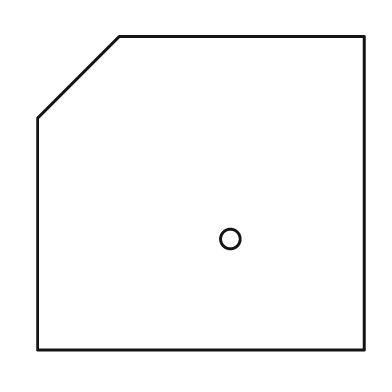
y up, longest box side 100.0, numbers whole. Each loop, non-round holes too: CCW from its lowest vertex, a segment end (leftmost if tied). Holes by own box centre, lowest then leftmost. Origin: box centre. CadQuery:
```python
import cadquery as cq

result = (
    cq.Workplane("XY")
    .moveTo(-50.0, -48.0)
    .lineTo(50.0, -48.0)
    .lineTo(50.0, 48.0)
    .lineTo(-25.0, 48.0)
    .lineTo(-50.0, 23.0)
    .close()
    .moveTo(9.0, -14.0)
    .circle(3.0)
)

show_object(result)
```